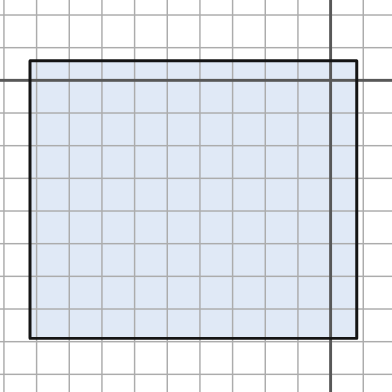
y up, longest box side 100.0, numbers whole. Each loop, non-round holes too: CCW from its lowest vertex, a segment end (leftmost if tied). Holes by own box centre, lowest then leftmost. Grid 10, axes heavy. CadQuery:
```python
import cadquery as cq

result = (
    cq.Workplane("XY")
    .moveTo(-92.0, -79.0)
    .lineTo(8.0, -79.0)
    .lineTo(8.0, 6.0)
    .lineTo(-92.0, 6.0)
    .close()
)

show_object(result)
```